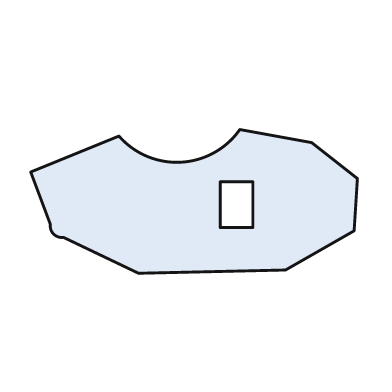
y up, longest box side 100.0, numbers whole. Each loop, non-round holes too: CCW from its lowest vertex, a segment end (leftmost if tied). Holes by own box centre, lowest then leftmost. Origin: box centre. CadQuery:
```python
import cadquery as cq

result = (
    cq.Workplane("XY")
    .moveTo(-17.0, -22.0)
    .lineTo(28.0, -21.0)
    .lineTo(49.0, -9.0)
    .lineTo(50.0, 7.0)
    .lineTo(36.0, 18.0)
    .lineTo(14.0, 22.0)
    .threePointArc((-4.0, 12.0), (-23.0, 20.0))
    .lineTo(-50.0, 9.0)
    .lineTo(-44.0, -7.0)
    .threePointArc((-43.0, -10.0), (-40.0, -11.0))
    .close()
    .moveTo(8.0, -8.0)
    .lineTo(18.0, -8.0)
    .lineTo(18.0, 6.0)
    .lineTo(8.0, 6.0)
    .close()
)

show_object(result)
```